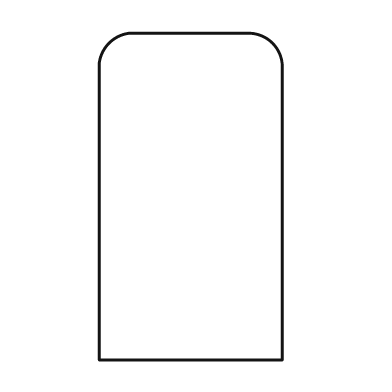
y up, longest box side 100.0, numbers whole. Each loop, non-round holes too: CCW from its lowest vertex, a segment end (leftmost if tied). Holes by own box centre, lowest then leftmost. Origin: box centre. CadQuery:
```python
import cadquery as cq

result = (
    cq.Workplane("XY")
    .moveTo(-28.0, -50.0)
    .lineTo(28.0, -50.0)
    .lineTo(28.0, 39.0)
    .threePointArc((25.0, 47.0), (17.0, 50.0))
    .lineTo(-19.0, 50.0)
    .threePointArc((-25.0, 47.0), (-28.0, 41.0))
    .close()
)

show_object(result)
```